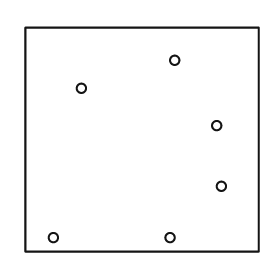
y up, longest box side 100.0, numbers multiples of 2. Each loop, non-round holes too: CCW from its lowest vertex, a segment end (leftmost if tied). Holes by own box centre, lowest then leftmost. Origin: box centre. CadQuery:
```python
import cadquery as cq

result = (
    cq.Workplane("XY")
    .moveTo(-50.0, -48.0)
    .lineTo(50.0, -48.0)
    .lineTo(50.0, 48.0)
    .lineTo(-50.0, 48.0)
    .close()
    .moveTo(-38.0, -42.0)
    .circle(2.0)
    .moveTo(12.0, -42.0)
    .circle(2.0)
    .moveTo(34.0, -20.0)
    .circle(2.0)
    .moveTo(32.0, 6.0)
    .circle(2.0)
    .moveTo(-26.0, 22.0)
    .circle(2.0)
    .moveTo(14.0, 34.0)
    .circle(2.0)
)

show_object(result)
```